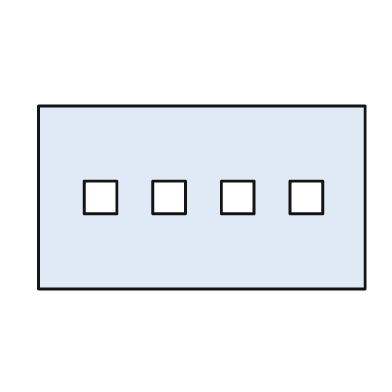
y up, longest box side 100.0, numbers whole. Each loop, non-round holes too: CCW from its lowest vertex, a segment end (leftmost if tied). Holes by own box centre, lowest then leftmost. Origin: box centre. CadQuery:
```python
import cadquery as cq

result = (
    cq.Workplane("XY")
    .moveTo(-50.0, -28.0)
    .lineTo(50.0, -28.0)
    .lineTo(50.0, 28.0)
    .lineTo(-50.0, 28.0)
    .close()
    .moveTo(-36.0, -5.0)
    .lineTo(-26.0, -5.0)
    .lineTo(-26.0, 5.0)
    .lineTo(-36.0, 5.0)
    .close()
    .moveTo(-15.0, -5.0)
    .lineTo(-5.0, -5.0)
    .lineTo(-5.0, 5.0)
    .lineTo(-15.0, 5.0)
    .close()
    .moveTo(6.0, -5.0)
    .lineTo(16.0, -5.0)
    .lineTo(16.0, 5.0)
    .lineTo(6.0, 5.0)
    .close()
    .moveTo(27.0, -5.0)
    .lineTo(37.0, -5.0)
    .lineTo(37.0, 5.0)
    .lineTo(27.0, 5.0)
    .close()
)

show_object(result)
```